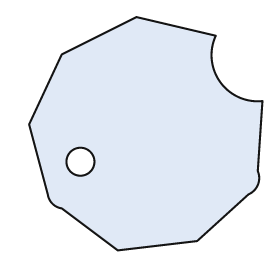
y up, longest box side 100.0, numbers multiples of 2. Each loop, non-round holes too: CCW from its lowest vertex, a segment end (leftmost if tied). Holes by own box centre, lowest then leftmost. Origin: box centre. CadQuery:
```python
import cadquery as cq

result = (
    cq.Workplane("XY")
    .moveTo(-12.0, -50.0)
    .lineTo(22.0, -46.0)
    .lineTo(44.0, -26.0)
    .threePointArc((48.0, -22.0), (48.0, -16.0))
    .lineTo(50.0, 14.0)
    .threePointArc((32.0, 22.0), (30.0, 42.0))
    .lineTo(-4.0, 50.0)
    .lineTo(-36.0, 34.0)
    .lineTo(-50.0, 4.0)
    .lineTo(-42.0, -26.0)
    .threePointArc((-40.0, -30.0), (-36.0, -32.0))
    .close()
    .moveTo(-28.0, -12.0)
    .circle(6.0)
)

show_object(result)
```